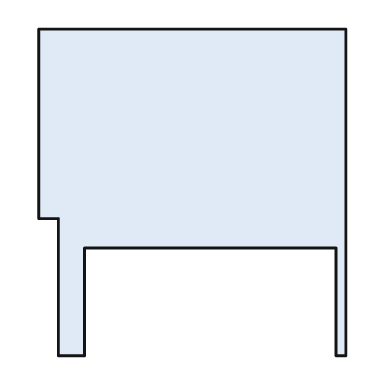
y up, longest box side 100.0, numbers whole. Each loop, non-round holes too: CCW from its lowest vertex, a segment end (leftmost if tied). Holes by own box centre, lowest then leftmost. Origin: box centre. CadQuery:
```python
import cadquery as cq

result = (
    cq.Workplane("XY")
    .moveTo(-41.0, -50.0)
    .lineTo(-33.0, -50.0)
    .lineTo(-33.0, -17.0)
    .lineTo(44.0, -17.0)
    .lineTo(44.0, -50.0)
    .lineTo(47.0, -50.0)
    .lineTo(47.0, 50.0)
    .lineTo(-47.0, 50.0)
    .lineTo(-47.0, -8.0)
    .lineTo(-41.0, -8.0)
    .close()
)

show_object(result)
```